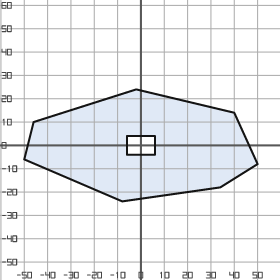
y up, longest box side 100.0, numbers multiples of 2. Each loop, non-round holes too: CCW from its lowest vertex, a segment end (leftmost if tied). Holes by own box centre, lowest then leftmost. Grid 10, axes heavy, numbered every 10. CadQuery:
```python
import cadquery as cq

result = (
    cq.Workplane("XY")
    .moveTo(-8.0, -24.0)
    .lineTo(34.0, -18.0)
    .lineTo(50.0, -8.0)
    .lineTo(40.0, 14.0)
    .lineTo(-2.0, 24.0)
    .lineTo(-46.0, 10.0)
    .lineTo(-50.0, -6.0)
    .close()
    .moveTo(-6.0, -4.0)
    .lineTo(6.0, -4.0)
    .lineTo(6.0, 4.0)
    .lineTo(-6.0, 4.0)
    .close()
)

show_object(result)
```